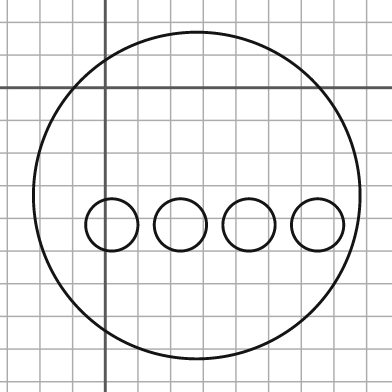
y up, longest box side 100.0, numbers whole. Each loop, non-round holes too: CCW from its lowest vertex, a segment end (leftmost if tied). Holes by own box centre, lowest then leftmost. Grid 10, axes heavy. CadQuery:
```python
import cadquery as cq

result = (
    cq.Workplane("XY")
    .moveTo(28.0, -33.0)
    .circle(50.0)
    .moveTo(2.0, -42.0)
    .circle(8.0)
    .moveTo(23.0, -42.0)
    .circle(8.0)
    .moveTo(44.0, -42.0)
    .circle(8.0)
    .moveTo(65.0, -42.0)
    .circle(8.0)
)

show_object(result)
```